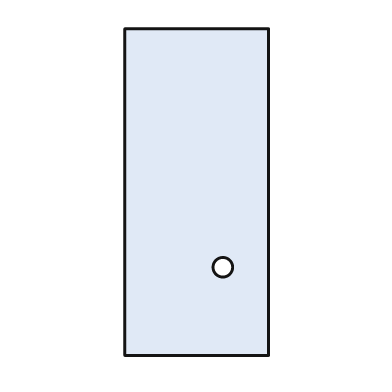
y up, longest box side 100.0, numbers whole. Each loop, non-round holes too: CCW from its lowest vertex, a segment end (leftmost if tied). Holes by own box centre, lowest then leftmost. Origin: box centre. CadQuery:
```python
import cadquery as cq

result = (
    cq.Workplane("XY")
    .moveTo(-22.0, -50.0)
    .lineTo(22.0, -50.0)
    .lineTo(22.0, 50.0)
    .lineTo(-22.0, 50.0)
    .close()
    .moveTo(8.0, -23.0)
    .circle(3.0)
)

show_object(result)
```